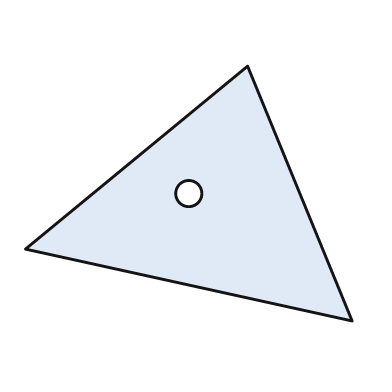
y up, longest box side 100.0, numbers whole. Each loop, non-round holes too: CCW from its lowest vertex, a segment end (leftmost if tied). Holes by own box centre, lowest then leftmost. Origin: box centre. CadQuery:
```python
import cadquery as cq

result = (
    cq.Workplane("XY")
    .moveTo(50.0, -39.0)
    .lineTo(18.0, 39.0)
    .lineTo(-50.0, -17.0)
    .close()
    .moveTo(0.0, 0.0)
    .circle(4.0)
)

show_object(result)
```